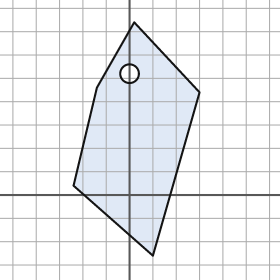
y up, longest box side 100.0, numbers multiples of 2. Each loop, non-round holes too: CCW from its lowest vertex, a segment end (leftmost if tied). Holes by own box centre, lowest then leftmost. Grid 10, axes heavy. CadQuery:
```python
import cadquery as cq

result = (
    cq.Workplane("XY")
    .moveTo(10.0, -26.0)
    .lineTo(30.0, 44.0)
    .lineTo(2.0, 74.0)
    .lineTo(-14.0, 46.0)
    .lineTo(-24.0, 4.0)
    .close()
    .moveTo(0.0, 52.0)
    .circle(4.0)
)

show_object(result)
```